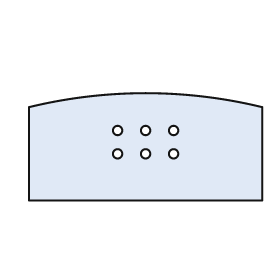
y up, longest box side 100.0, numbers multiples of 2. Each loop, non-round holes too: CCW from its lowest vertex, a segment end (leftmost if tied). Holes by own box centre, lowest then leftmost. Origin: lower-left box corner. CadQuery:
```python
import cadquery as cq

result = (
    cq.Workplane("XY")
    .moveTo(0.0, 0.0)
    .lineTo(100.0, 0.0)
    .lineTo(100.0, 40.0)
    .threePointArc((50.0, 46.0), (0.0, 40.0))
    .close()
    .moveTo(38.0, 20.0)
    .circle(2.0)
    .moveTo(50.0, 20.0)
    .circle(2.0)
    .moveTo(62.0, 20.0)
    .circle(2.0)
    .moveTo(38.0, 30.0)
    .circle(2.0)
    .moveTo(50.0, 30.0)
    .circle(2.0)
    .moveTo(62.0, 30.0)
    .circle(2.0)
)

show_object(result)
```